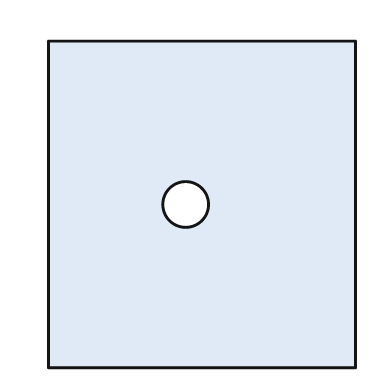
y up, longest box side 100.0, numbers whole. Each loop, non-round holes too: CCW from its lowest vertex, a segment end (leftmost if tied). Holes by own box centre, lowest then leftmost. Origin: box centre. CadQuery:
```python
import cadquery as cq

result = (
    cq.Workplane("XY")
    .moveTo(-47.0, -50.0)
    .lineTo(47.0, -50.0)
    .lineTo(47.0, 50.0)
    .lineTo(-47.0, 50.0)
    .close()
    .moveTo(-5.0, 0.0)
    .circle(7.0)
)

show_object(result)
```